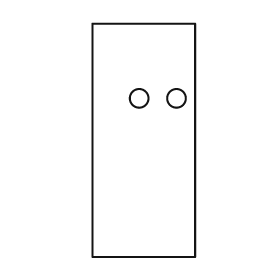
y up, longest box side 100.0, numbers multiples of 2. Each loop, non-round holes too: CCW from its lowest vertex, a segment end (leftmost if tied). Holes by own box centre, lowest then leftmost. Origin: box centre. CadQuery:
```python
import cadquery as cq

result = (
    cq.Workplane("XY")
    .moveTo(-22.0, -50.0)
    .lineTo(22.0, -50.0)
    .lineTo(22.0, 50.0)
    .lineTo(-22.0, 50.0)
    .close()
    .moveTo(-2.0, 18.0)
    .circle(4.0)
    .moveTo(14.0, 18.0)
    .circle(4.0)
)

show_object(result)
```